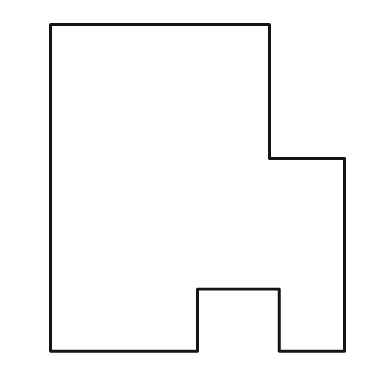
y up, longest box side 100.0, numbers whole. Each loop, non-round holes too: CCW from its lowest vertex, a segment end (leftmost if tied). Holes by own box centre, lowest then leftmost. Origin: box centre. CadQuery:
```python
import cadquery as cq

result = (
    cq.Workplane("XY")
    .moveTo(-45.0, -50.0)
    .lineTo(0.0, -50.0)
    .lineTo(0.0, -31.0)
    .lineTo(25.0, -31.0)
    .lineTo(25.0, -50.0)
    .lineTo(45.0, -50.0)
    .lineTo(45.0, 9.0)
    .lineTo(22.0, 9.0)
    .lineTo(22.0, 50.0)
    .lineTo(-45.0, 50.0)
    .close()
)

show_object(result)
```